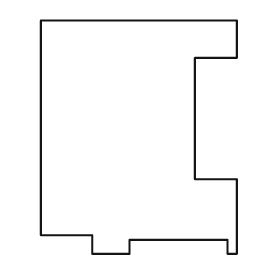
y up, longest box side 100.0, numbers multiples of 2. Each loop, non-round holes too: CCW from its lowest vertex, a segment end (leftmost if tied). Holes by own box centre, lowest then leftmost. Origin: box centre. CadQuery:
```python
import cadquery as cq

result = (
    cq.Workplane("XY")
    .moveTo(-20.0, -50.0)
    .lineTo(-4.0, -50.0)
    .lineTo(-4.0, -44.0)
    .lineTo(38.0, -44.0)
    .lineTo(38.0, -50.0)
    .lineTo(42.0, -50.0)
    .lineTo(42.0, -18.0)
    .lineTo(24.0, -18.0)
    .lineTo(24.0, 34.0)
    .lineTo(42.0, 34.0)
    .lineTo(42.0, 50.0)
    .lineTo(-42.0, 50.0)
    .lineTo(-42.0, -42.0)
    .lineTo(-20.0, -42.0)
    .close()
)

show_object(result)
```